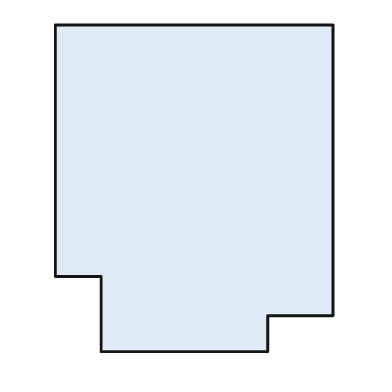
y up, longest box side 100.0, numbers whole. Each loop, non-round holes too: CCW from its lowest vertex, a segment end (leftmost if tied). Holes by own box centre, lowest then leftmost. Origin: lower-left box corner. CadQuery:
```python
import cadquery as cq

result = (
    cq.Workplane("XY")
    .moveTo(14.0, 0.0)
    .lineTo(65.0, 0.0)
    .lineTo(65.0, 11.0)
    .lineTo(85.0, 11.0)
    .lineTo(85.0, 100.0)
    .lineTo(0.0, 100.0)
    .lineTo(0.0, 23.0)
    .lineTo(14.0, 23.0)
    .close()
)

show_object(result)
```